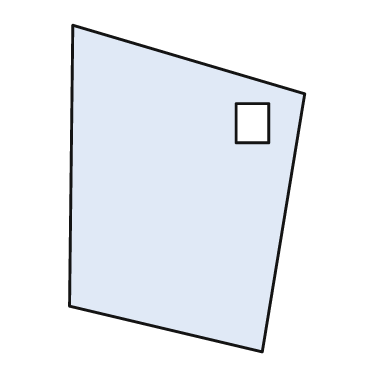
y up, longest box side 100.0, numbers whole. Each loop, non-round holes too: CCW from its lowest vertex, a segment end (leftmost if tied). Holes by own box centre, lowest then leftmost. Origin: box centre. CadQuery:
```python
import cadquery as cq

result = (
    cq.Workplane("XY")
    .moveTo(23.0, -50.0)
    .lineTo(36.0, 29.0)
    .lineTo(-35.0, 50.0)
    .lineTo(-36.0, -36.0)
    .close()
    .moveTo(15.0, 14.0)
    .lineTo(25.0, 14.0)
    .lineTo(25.0, 26.0)
    .lineTo(15.0, 26.0)
    .close()
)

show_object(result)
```